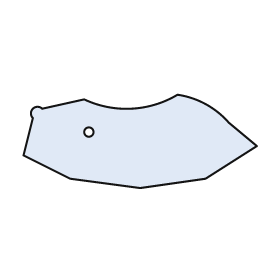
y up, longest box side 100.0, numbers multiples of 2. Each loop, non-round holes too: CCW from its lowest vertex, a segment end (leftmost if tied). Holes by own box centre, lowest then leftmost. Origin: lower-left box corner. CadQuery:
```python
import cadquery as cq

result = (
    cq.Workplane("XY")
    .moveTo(50.0, 0.0)
    .lineTo(78.0, 4.0)
    .lineTo(100.0, 18.0)
    .lineTo(88.0, 28.0)
    .threePointArc((78.0, 36.0), (66.0, 40.0))
    .threePointArc((46.0, 34.0), (26.0, 38.0))
    .lineTo(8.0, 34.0)
    .threePointArc((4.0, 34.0), (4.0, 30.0))
    .lineTo(0.0, 14.0)
    .lineTo(20.0, 4.0)
    .close()
    .moveTo(28.0, 24.0)
    .circle(2.0)
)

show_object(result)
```